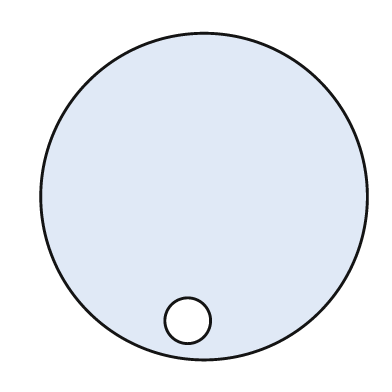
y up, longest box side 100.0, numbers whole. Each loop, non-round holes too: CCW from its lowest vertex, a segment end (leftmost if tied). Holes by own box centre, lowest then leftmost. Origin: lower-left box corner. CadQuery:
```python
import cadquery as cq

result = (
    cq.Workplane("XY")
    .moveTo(50.0, 50.0)
    .circle(50.0)
    .moveTo(45.0, 12.0)
    .circle(7.0)
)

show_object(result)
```